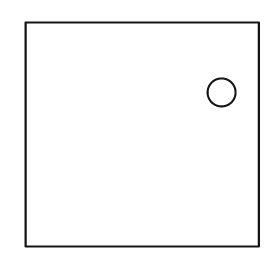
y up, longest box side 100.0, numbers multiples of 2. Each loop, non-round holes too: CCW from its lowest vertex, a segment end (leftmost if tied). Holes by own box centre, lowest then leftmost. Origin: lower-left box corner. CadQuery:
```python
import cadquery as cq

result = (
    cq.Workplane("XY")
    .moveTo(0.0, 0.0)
    .lineTo(100.0, 0.0)
    .lineTo(100.0, 96.0)
    .lineTo(0.0, 96.0)
    .close()
    .moveTo(84.0, 66.0)
    .circle(6.0)
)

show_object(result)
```